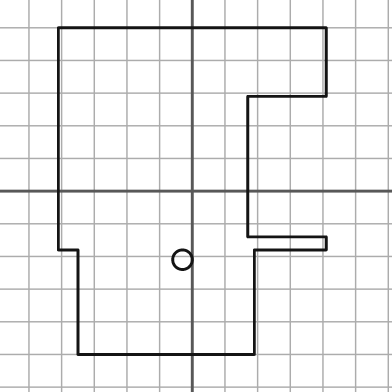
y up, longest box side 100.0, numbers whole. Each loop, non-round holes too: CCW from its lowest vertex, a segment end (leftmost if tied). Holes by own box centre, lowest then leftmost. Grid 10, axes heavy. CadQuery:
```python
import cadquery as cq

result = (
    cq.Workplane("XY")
    .moveTo(-35.0, -50.0)
    .lineTo(19.0, -50.0)
    .lineTo(19.0, -18.0)
    .lineTo(41.0, -18.0)
    .lineTo(41.0, -14.0)
    .lineTo(17.0, -14.0)
    .lineTo(17.0, 29.0)
    .lineTo(41.0, 29.0)
    .lineTo(41.0, 50.0)
    .lineTo(-41.0, 50.0)
    .lineTo(-41.0, -18.0)
    .lineTo(-35.0, -18.0)
    .close()
    .moveTo(-3.0, -21.0)
    .circle(3.0)
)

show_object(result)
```